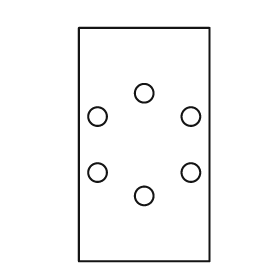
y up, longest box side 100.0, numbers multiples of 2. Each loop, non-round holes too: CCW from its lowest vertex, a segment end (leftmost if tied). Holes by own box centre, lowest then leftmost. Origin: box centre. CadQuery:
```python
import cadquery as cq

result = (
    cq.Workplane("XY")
    .moveTo(-28.0, -50.0)
    .lineTo(28.0, -50.0)
    .lineTo(28.0, 50.0)
    .lineTo(-28.0, 50.0)
    .close()
    .moveTo(0.0, -22.0)
    .circle(4.0)
    .moveTo(-20.0, -12.0)
    .circle(4.0)
    .moveTo(20.0, -12.0)
    .circle(4.0)
    .moveTo(-20.0, 12.0)
    .circle(4.0)
    .moveTo(20.0, 12.0)
    .circle(4.0)
    .moveTo(0.0, 22.0)
    .circle(4.0)
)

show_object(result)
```